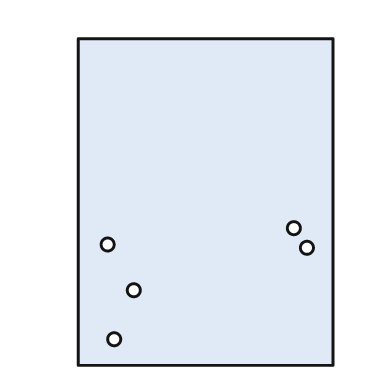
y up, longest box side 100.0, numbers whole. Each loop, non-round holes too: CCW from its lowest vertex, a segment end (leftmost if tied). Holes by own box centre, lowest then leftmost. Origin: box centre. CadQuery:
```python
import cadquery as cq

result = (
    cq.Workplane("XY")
    .moveTo(-39.0, -50.0)
    .lineTo(39.0, -50.0)
    .lineTo(39.0, 50.0)
    .lineTo(-39.0, 50.0)
    .close()
    .moveTo(-28.0, -42.0)
    .circle(2.0)
    .moveTo(-22.0, -27.0)
    .circle(2.0)
    .moveTo(31.0, -14.0)
    .circle(2.0)
    .moveTo(-30.0, -13.0)
    .circle(2.0)
    .moveTo(27.0, -8.0)
    .circle(2.0)
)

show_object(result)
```